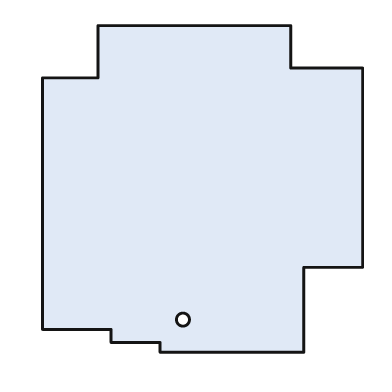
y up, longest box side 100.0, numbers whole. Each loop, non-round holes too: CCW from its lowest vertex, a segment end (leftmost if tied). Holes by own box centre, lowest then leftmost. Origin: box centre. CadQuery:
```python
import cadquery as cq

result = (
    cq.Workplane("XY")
    .moveTo(-13.0, -50.0)
    .lineTo(31.0, -50.0)
    .lineTo(31.0, -24.0)
    .lineTo(49.0, -24.0)
    .lineTo(49.0, 37.0)
    .lineTo(27.0, 37.0)
    .lineTo(27.0, 50.0)
    .lineTo(-32.0, 50.0)
    .lineTo(-32.0, 34.0)
    .lineTo(-49.0, 34.0)
    .lineTo(-49.0, -43.0)
    .lineTo(-28.0, -43.0)
    .lineTo(-28.0, -47.0)
    .lineTo(-13.0, -47.0)
    .close()
    .moveTo(-6.0, -40.0)
    .circle(2.0)
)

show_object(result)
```